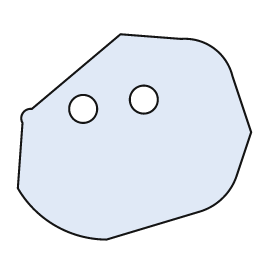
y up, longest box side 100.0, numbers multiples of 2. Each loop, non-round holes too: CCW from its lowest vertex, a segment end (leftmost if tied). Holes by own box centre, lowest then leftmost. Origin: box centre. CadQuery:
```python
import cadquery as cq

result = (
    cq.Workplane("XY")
    .moveTo(-12.0, -44.0)
    .lineTo(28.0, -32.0)
    .threePointArc((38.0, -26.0), (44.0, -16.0))
    .lineTo(50.0, 2.0)
    .lineTo(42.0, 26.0)
    .threePointArc((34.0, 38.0), (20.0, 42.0))
    .lineTo(-6.0, 44.0)
    .lineTo(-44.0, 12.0)
    .threePointArc((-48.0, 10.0), (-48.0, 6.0))
    .lineTo(-50.0, -22.0)
    .threePointArc((-34.0, -38.0), (-12.0, -44.0))
    .close()
    .moveTo(-22.0, 12.0)
    .circle(6.0)
    .moveTo(4.0, 16.0)
    .circle(6.0)
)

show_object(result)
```